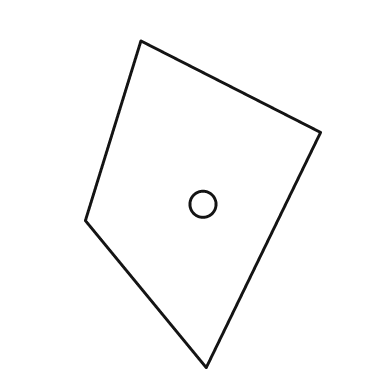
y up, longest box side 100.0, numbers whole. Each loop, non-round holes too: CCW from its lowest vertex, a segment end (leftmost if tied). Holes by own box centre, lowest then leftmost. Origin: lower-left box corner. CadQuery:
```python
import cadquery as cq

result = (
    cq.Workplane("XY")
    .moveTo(37.0, 0.0)
    .lineTo(72.0, 72.0)
    .lineTo(17.0, 100.0)
    .lineTo(0.0, 45.0)
    .close()
    .moveTo(36.0, 50.0)
    .circle(4.0)
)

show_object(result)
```